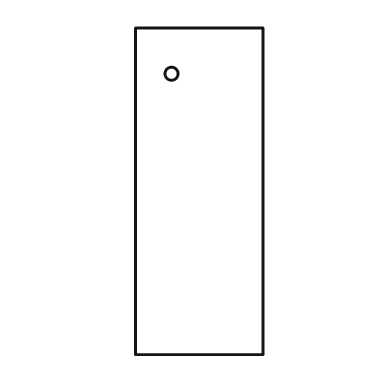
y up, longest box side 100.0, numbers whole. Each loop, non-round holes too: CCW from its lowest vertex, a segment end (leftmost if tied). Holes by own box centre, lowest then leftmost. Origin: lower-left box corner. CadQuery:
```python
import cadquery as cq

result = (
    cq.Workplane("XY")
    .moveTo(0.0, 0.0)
    .lineTo(39.0, 0.0)
    .lineTo(39.0, 100.0)
    .lineTo(0.0, 100.0)
    .close()
    .moveTo(11.0, 86.0)
    .circle(2.0)
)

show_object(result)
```